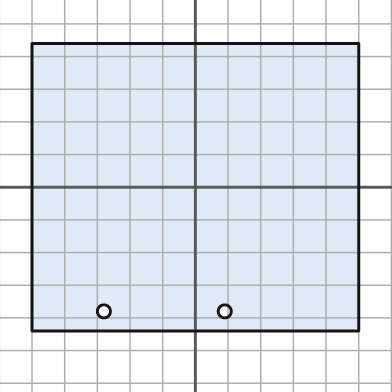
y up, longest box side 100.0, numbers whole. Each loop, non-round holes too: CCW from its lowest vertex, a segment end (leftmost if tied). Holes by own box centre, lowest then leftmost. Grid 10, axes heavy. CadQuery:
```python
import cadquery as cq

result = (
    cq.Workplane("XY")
    .moveTo(-50.0, -44.0)
    .lineTo(50.0, -44.0)
    .lineTo(50.0, 44.0)
    .lineTo(-50.0, 44.0)
    .close()
    .moveTo(-28.0, -38.0)
    .circle(2.0)
    .moveTo(9.0, -38.0)
    .circle(2.0)
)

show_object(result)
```